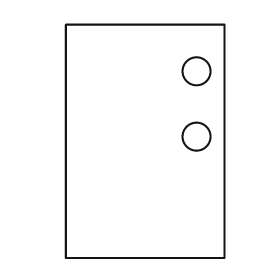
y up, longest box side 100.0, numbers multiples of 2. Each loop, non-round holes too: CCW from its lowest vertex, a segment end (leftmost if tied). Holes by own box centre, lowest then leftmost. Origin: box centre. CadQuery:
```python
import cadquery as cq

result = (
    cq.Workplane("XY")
    .moveTo(-34.0, -50.0)
    .lineTo(34.0, -50.0)
    .lineTo(34.0, 50.0)
    .lineTo(-34.0, 50.0)
    .close()
    .moveTo(22.0, 2.0)
    .circle(6.0)
    .moveTo(22.0, 30.0)
    .circle(6.0)
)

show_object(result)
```